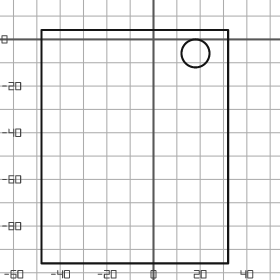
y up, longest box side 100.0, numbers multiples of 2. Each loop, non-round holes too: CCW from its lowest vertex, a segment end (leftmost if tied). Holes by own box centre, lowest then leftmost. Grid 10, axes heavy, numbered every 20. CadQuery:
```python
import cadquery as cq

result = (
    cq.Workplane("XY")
    .moveTo(-48.0, -96.0)
    .lineTo(32.0, -96.0)
    .lineTo(32.0, 4.0)
    .lineTo(-48.0, 4.0)
    .close()
    .moveTo(18.0, -6.0)
    .circle(6.0)
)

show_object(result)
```